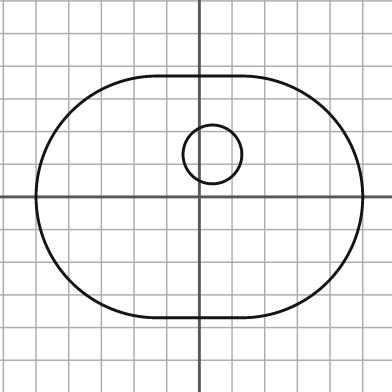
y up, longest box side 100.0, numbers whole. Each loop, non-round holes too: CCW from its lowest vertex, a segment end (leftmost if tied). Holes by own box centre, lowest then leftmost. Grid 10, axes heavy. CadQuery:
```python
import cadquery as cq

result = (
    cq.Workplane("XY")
    .moveTo(-13.0, -37.0)
    .lineTo(13.0, -37.0)
    .threePointArc((50.0, 0.0), (13.0, 37.0))
    .lineTo(-13.0, 37.0)
    .threePointArc((-50.0, 0.0), (-13.0, -37.0))
    .close()
    .moveTo(4.0, 13.0)
    .circle(9.0)
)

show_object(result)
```